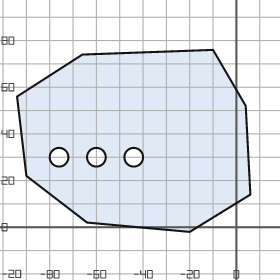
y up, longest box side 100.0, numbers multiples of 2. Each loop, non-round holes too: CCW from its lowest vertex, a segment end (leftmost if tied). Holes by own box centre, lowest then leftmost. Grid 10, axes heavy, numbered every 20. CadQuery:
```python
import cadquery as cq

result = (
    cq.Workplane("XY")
    .moveTo(-20.0, -2.0)
    .lineTo(6.0, 14.0)
    .lineTo(4.0, 52.0)
    .lineTo(-10.0, 76.0)
    .lineTo(-66.0, 74.0)
    .lineTo(-94.0, 56.0)
    .lineTo(-90.0, 22.0)
    .lineTo(-64.0, 2.0)
    .close()
    .moveTo(-76.0, 30.0)
    .circle(4.0)
    .moveTo(-60.0, 30.0)
    .circle(4.0)
    .moveTo(-44.0, 30.0)
    .circle(4.0)
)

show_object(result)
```